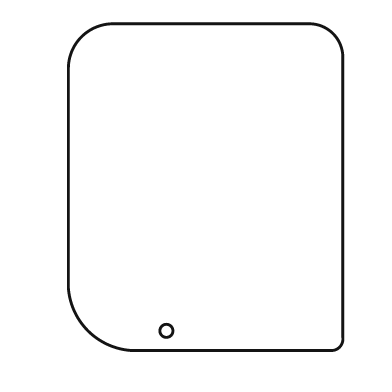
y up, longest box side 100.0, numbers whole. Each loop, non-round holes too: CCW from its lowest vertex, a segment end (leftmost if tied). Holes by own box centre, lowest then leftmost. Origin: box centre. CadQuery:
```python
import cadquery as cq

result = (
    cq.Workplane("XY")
    .moveTo(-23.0, -50.0)
    .lineTo(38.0, -50.0)
    .threePointArc((41.0, -49.0), (42.0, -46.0))
    .lineTo(42.0, 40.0)
    .threePointArc((39.0, 47.0), (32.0, 50.0))
    .lineTo(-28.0, 50.0)
    .threePointArc((-38.0, 46.0), (-42.0, 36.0))
    .lineTo(-42.0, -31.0)
    .threePointArc((-36.0, -44.0), (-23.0, -50.0))
    .close()
    .moveTo(-12.0, -44.0)
    .circle(2.0)
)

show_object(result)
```